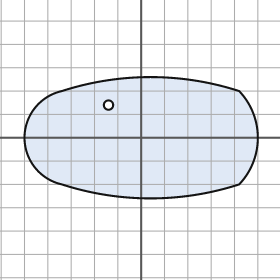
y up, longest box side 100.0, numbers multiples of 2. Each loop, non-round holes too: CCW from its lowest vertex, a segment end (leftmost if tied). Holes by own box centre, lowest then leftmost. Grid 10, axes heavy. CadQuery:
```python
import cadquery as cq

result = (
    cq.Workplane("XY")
    .moveTo(-34.0, -20.0)
    .threePointArc((4.0, -26.0), (42.0, -20.0))
    .threePointArc((50.0, 0.0), (42.0, 20.0))
    .threePointArc((4.0, 26.0), (-34.0, 20.0))
    .threePointArc((-50.0, 0.0), (-34.0, -20.0))
    .close()
    .moveTo(-14.0, 14.0)
    .circle(2.0)
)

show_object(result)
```